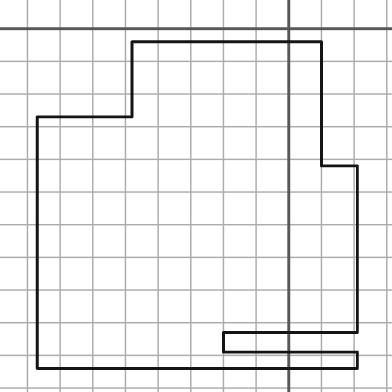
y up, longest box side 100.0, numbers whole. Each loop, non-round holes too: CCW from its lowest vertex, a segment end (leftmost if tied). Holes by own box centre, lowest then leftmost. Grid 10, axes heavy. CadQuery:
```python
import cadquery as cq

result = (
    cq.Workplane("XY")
    .moveTo(-77.0, -104.0)
    .lineTo(21.0, -104.0)
    .lineTo(21.0, -99.0)
    .lineTo(-20.0, -99.0)
    .lineTo(-20.0, -93.0)
    .lineTo(21.0, -93.0)
    .lineTo(21.0, -42.0)
    .lineTo(10.0, -42.0)
    .lineTo(10.0, -4.0)
    .lineTo(-48.0, -4.0)
    .lineTo(-48.0, -27.0)
    .lineTo(-77.0, -27.0)
    .close()
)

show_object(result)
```